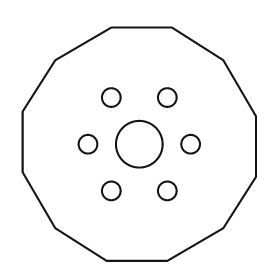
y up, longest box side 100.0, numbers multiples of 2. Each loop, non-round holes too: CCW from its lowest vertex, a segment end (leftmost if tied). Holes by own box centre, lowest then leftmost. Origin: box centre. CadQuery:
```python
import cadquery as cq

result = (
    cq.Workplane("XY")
    .moveTo(-14.0, -50.0)
    .lineTo(12.0, -50.0)
    .lineTo(36.0, -36.0)
    .lineTo(50.0, -14.0)
    .lineTo(50.0, 12.0)
    .lineTo(36.0, 36.0)
    .lineTo(14.0, 50.0)
    .lineTo(-12.0, 50.0)
    .lineTo(-36.0, 36.0)
    .lineTo(-50.0, 14.0)
    .lineTo(-50.0, -12.0)
    .lineTo(-36.0, -36.0)
    .close()
    .moveTo(-12.0, -20.0)
    .circle(4.0)
    .moveTo(12.0, -20.0)
    .circle(4.0)
    .moveTo(-22.0, 0.0)
    .circle(4.0)
    .moveTo(0.0, 0.0)
    .circle(10.0)
    .moveTo(22.0, 0.0)
    .circle(4.0)
    .moveTo(-12.0, 20.0)
    .circle(4.0)
    .moveTo(12.0, 20.0)
    .circle(4.0)
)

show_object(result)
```